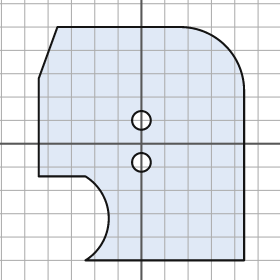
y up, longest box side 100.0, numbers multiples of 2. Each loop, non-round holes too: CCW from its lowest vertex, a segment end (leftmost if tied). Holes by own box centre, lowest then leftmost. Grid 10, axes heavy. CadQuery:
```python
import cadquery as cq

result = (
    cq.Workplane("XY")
    .moveTo(-24.0, -50.0)
    .lineTo(44.0, -50.0)
    .lineTo(44.0, 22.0)
    .threePointArc((36.0, 42.0), (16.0, 50.0))
    .lineTo(-36.0, 50.0)
    .lineTo(-44.0, 28.0)
    .lineTo(-44.0, -14.0)
    .lineTo(-24.0, -14.0)
    .threePointArc((-14.0, -32.0), (-24.0, -50.0))
    .close()
    .moveTo(0.0, -8.0)
    .circle(4.0)
    .moveTo(0.0, 10.0)
    .circle(4.0)
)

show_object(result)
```